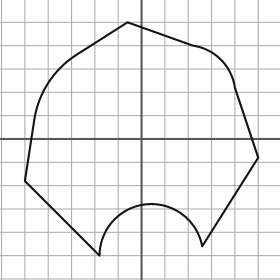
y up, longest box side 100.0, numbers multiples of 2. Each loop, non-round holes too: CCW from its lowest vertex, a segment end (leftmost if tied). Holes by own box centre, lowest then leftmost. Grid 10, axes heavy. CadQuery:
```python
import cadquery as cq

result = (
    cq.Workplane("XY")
    .moveTo(-18.0, -50.0)
    .threePointArc((2.0, -28.0), (26.0, -46.0))
    .lineTo(50.0, -8.0)
    .lineTo(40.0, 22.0)
    .threePointArc((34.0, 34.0), (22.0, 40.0))
    .lineTo(-6.0, 50.0)
    .lineTo(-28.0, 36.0)
    .threePointArc((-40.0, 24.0), (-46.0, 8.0))
    .lineTo(-50.0, -18.0)
    .close()
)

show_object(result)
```